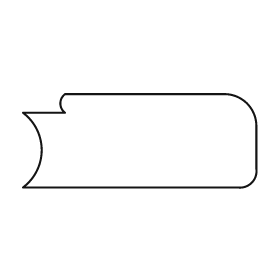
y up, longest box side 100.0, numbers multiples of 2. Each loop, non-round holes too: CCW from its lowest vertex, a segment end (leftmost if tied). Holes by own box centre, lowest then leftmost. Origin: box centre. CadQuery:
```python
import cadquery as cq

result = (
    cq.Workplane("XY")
    .moveTo(-50.0, -20.0)
    .lineTo(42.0, -20.0)
    .threePointArc((48.0, -18.0), (50.0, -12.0))
    .lineTo(50.0, 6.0)
    .threePointArc((46.0, 16.0), (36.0, 20.0))
    .lineTo(-32.0, 20.0)
    .threePointArc((-34.0, 16.0), (-32.0, 12.0))
    .lineTo(-50.0, 12.0)
    .threePointArc((-42.0, -4.0), (-50.0, -20.0))
    .close()
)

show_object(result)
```